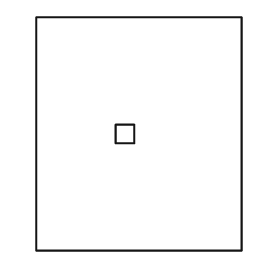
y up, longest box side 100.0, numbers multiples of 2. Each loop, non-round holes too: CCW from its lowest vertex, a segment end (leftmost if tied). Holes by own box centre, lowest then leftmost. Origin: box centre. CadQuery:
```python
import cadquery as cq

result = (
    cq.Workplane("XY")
    .moveTo(-44.0, -50.0)
    .lineTo(44.0, -50.0)
    .lineTo(44.0, 50.0)
    .lineTo(-44.0, 50.0)
    .close()
    .moveTo(-10.0, -4.0)
    .lineTo(-2.0, -4.0)
    .lineTo(-2.0, 4.0)
    .lineTo(-10.0, 4.0)
    .close()
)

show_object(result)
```